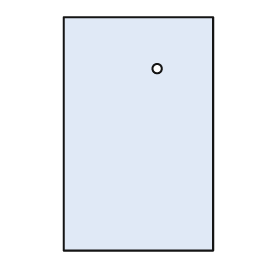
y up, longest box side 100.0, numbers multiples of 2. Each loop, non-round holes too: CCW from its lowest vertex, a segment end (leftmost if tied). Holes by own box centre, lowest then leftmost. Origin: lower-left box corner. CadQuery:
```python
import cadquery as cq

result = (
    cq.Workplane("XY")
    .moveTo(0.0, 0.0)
    .lineTo(64.0, 0.0)
    .lineTo(64.0, 100.0)
    .lineTo(0.0, 100.0)
    .close()
    .moveTo(40.0, 78.0)
    .circle(2.0)
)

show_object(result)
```